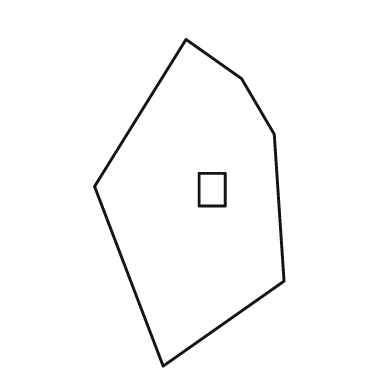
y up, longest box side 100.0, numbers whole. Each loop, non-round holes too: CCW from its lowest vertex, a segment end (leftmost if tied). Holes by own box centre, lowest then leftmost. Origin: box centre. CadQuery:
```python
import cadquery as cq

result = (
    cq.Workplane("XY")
    .moveTo(-8.0, -50.0)
    .lineTo(29.0, -24.0)
    .lineTo(26.0, 21.0)
    .lineTo(16.0, 38.0)
    .lineTo(-1.0, 50.0)
    .lineTo(-29.0, 5.0)
    .close()
    .moveTo(3.0, -1.0)
    .lineTo(11.0, -1.0)
    .lineTo(11.0, 9.0)
    .lineTo(3.0, 9.0)
    .close()
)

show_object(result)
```